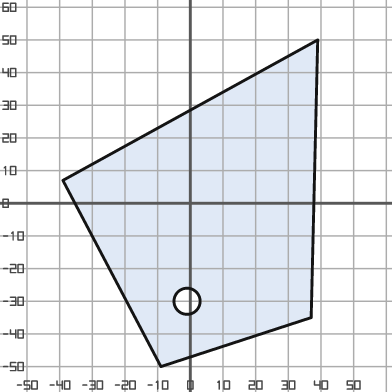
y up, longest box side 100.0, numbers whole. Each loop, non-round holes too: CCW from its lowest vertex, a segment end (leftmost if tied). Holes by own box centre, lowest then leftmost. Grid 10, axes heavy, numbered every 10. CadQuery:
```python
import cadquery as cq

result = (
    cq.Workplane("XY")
    .moveTo(-9.0, -50.0)
    .lineTo(37.0, -35.0)
    .lineTo(39.0, 50.0)
    .lineTo(-39.0, 7.0)
    .close()
    .moveTo(-1.0, -30.0)
    .circle(4.0)
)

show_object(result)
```